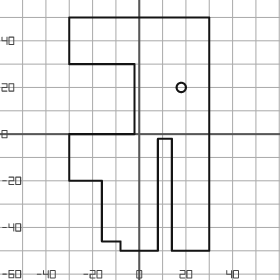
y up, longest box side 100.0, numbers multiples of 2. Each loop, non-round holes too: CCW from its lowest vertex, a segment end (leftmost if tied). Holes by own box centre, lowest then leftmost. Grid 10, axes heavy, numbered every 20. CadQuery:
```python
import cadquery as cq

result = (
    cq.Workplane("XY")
    .moveTo(-8.0, -50.0)
    .lineTo(8.0, -50.0)
    .lineTo(8.0, -2.0)
    .lineTo(14.0, -2.0)
    .lineTo(14.0, -50.0)
    .lineTo(30.0, -50.0)
    .lineTo(30.0, 50.0)
    .lineTo(-30.0, 50.0)
    .lineTo(-30.0, 30.0)
    .lineTo(-2.0, 30.0)
    .lineTo(-2.0, 0.0)
    .lineTo(-30.0, 0.0)
    .lineTo(-30.0, -20.0)
    .lineTo(-16.0, -20.0)
    .lineTo(-16.0, -46.0)
    .lineTo(-8.0, -46.0)
    .close()
    .moveTo(18.0, 20.0)
    .circle(2.0)
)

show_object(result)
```